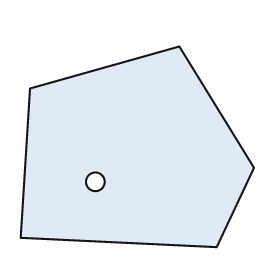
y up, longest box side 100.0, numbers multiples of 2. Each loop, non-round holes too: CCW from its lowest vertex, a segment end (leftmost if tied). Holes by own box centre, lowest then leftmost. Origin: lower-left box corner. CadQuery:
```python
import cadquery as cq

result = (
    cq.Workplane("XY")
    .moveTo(84.0, 0.0)
    .lineTo(100.0, 34.0)
    .lineTo(68.0, 86.0)
    .lineTo(4.0, 68.0)
    .lineTo(0.0, 4.0)
    .close()
    .moveTo(32.0, 28.0)
    .circle(4.0)
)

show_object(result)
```